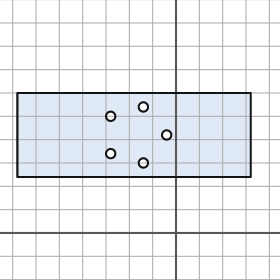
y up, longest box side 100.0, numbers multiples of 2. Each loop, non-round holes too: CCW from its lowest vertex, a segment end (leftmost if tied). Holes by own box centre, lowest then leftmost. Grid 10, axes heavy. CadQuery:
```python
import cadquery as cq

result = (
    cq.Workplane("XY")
    .moveTo(-68.0, 24.0)
    .lineTo(32.0, 24.0)
    .lineTo(32.0, 60.0)
    .lineTo(-68.0, 60.0)
    .close()
    .moveTo(-14.0, 30.0)
    .circle(2.0)
    .moveTo(-28.0, 34.0)
    .circle(2.0)
    .moveTo(-4.0, 42.0)
    .circle(2.0)
    .moveTo(-28.0, 50.0)
    .circle(2.0)
    .moveTo(-14.0, 54.0)
    .circle(2.0)
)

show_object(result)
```